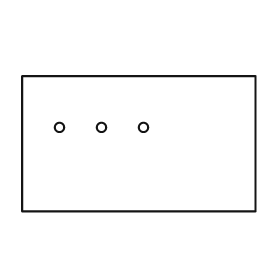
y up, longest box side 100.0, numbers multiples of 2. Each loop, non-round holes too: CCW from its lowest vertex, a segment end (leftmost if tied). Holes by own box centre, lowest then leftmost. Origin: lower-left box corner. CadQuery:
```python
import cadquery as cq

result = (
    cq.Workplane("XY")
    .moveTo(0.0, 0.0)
    .lineTo(100.0, 0.0)
    .lineTo(100.0, 58.0)
    .lineTo(0.0, 58.0)
    .close()
    .moveTo(16.0, 36.0)
    .circle(2.0)
    .moveTo(34.0, 36.0)
    .circle(2.0)
    .moveTo(52.0, 36.0)
    .circle(2.0)
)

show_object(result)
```